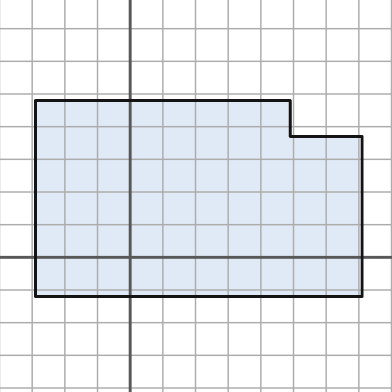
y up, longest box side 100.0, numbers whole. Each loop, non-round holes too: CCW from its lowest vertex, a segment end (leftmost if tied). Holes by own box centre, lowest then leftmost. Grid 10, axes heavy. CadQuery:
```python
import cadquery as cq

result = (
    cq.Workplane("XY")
    .moveTo(-29.0, -12.0)
    .lineTo(71.0, -12.0)
    .lineTo(71.0, 37.0)
    .lineTo(49.0, 37.0)
    .lineTo(49.0, 48.0)
    .lineTo(-29.0, 48.0)
    .close()
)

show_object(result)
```